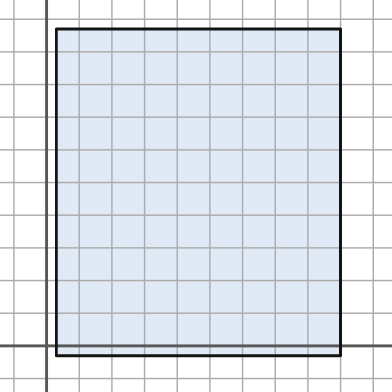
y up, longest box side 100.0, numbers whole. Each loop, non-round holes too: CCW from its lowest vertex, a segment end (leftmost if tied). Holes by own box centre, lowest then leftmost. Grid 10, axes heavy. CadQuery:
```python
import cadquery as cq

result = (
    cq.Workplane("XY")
    .moveTo(3.0, -3.0)
    .lineTo(90.0, -3.0)
    .lineTo(90.0, 97.0)
    .lineTo(3.0, 97.0)
    .close()
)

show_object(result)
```